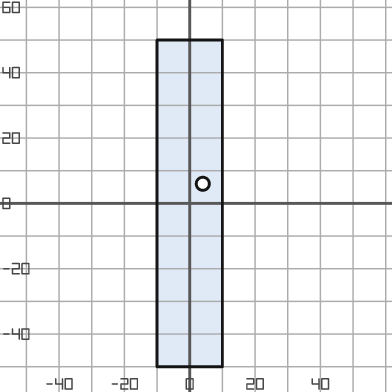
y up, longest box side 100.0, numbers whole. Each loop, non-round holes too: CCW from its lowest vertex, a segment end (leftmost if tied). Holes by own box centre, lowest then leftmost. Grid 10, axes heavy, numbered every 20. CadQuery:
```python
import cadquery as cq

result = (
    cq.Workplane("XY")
    .moveTo(-10.0, -50.0)
    .lineTo(10.0, -50.0)
    .lineTo(10.0, 50.0)
    .lineTo(-10.0, 50.0)
    .close()
    .moveTo(4.0, 6.0)
    .circle(2.0)
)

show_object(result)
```